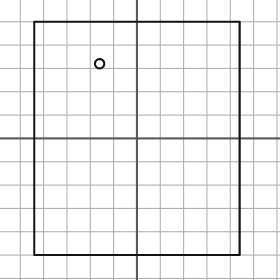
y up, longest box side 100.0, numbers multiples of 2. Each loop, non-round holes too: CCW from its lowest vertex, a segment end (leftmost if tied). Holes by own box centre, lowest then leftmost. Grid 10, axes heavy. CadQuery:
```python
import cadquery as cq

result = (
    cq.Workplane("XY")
    .moveTo(-44.0, -50.0)
    .lineTo(44.0, -50.0)
    .lineTo(44.0, 50.0)
    .lineTo(-44.0, 50.0)
    .close()
    .moveTo(-16.0, 32.0)
    .circle(2.0)
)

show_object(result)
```